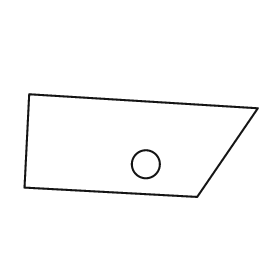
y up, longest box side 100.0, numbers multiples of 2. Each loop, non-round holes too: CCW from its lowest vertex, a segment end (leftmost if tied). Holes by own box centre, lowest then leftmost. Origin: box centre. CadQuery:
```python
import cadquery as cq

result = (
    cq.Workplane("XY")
    .moveTo(24.0, -22.0)
    .lineTo(50.0, 16.0)
    .lineTo(-48.0, 22.0)
    .lineTo(-50.0, -18.0)
    .close()
    .moveTo(2.0, -8.0)
    .circle(6.0)
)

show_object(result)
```